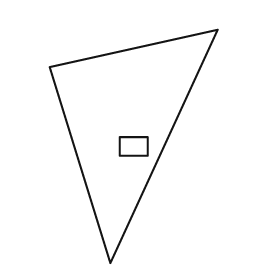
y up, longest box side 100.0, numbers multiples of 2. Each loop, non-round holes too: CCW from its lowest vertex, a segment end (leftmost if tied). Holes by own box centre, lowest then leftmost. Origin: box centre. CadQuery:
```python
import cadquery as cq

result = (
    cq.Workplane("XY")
    .moveTo(-10.0, -50.0)
    .lineTo(36.0, 50.0)
    .lineTo(-36.0, 34.0)
    .close()
    .moveTo(-6.0, -4.0)
    .lineTo(6.0, -4.0)
    .lineTo(6.0, 4.0)
    .lineTo(-6.0, 4.0)
    .close()
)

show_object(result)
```